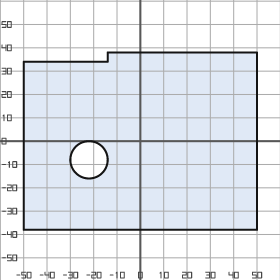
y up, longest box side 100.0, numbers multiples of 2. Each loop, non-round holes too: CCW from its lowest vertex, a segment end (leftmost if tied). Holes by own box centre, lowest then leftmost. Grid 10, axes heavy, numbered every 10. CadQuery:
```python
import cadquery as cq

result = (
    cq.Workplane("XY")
    .moveTo(-50.0, -38.0)
    .lineTo(50.0, -38.0)
    .lineTo(50.0, 38.0)
    .lineTo(-14.0, 38.0)
    .lineTo(-14.0, 34.0)
    .lineTo(-50.0, 34.0)
    .close()
    .moveTo(-22.0, -8.0)
    .circle(8.0)
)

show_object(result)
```